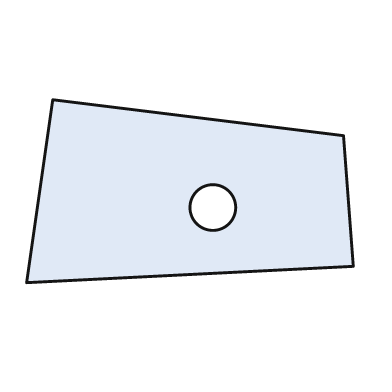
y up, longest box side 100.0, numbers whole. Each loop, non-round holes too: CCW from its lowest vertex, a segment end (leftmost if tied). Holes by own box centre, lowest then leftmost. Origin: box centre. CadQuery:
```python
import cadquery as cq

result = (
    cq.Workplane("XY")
    .moveTo(-50.0, -28.0)
    .lineTo(50.0, -23.0)
    .lineTo(47.0, 17.0)
    .lineTo(-42.0, 28.0)
    .close()
    .moveTo(7.0, -5.0)
    .circle(7.0)
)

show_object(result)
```